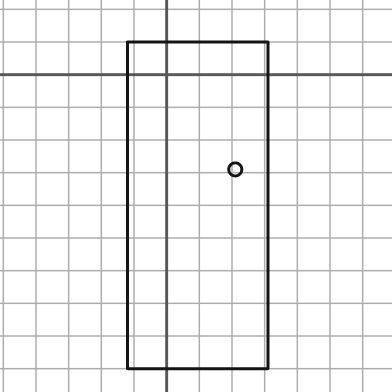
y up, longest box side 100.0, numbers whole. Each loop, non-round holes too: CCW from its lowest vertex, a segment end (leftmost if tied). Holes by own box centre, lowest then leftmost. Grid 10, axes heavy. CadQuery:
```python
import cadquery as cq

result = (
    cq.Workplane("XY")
    .moveTo(-12.0, -90.0)
    .lineTo(31.0, -90.0)
    .lineTo(31.0, 10.0)
    .lineTo(-12.0, 10.0)
    .close()
    .moveTo(21.0, -29.0)
    .circle(2.0)
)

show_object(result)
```